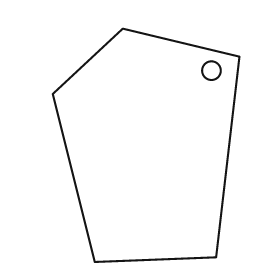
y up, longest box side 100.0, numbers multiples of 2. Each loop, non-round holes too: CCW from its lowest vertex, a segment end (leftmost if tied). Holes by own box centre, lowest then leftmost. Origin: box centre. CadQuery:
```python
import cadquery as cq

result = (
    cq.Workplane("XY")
    .moveTo(-22.0, -50.0)
    .lineTo(30.0, -48.0)
    .lineTo(40.0, 38.0)
    .lineTo(-10.0, 50.0)
    .lineTo(-40.0, 22.0)
    .close()
    .moveTo(28.0, 32.0)
    .circle(4.0)
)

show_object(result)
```